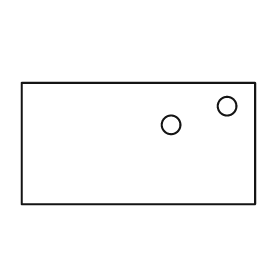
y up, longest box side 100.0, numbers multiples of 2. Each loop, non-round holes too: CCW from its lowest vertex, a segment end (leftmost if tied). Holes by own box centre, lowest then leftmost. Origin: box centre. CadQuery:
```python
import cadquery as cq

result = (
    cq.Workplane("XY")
    .moveTo(-50.0, -26.0)
    .lineTo(50.0, -26.0)
    .lineTo(50.0, 26.0)
    .lineTo(-50.0, 26.0)
    .close()
    .moveTo(14.0, 8.0)
    .circle(4.0)
    .moveTo(38.0, 16.0)
    .circle(4.0)
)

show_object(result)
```